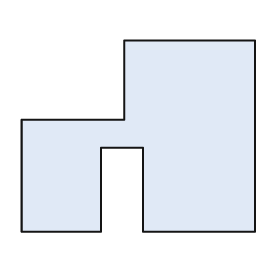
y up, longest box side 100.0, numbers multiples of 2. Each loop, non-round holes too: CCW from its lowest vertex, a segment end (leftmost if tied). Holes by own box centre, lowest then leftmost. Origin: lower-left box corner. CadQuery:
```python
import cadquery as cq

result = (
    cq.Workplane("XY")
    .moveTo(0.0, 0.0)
    .lineTo(34.0, 0.0)
    .lineTo(34.0, 36.0)
    .lineTo(52.0, 36.0)
    .lineTo(52.0, 0.0)
    .lineTo(100.0, 0.0)
    .lineTo(100.0, 82.0)
    .lineTo(44.0, 82.0)
    .lineTo(44.0, 48.0)
    .lineTo(0.0, 48.0)
    .close()
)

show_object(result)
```